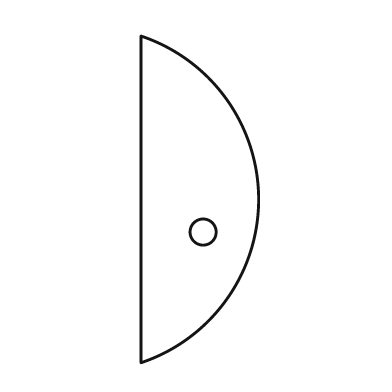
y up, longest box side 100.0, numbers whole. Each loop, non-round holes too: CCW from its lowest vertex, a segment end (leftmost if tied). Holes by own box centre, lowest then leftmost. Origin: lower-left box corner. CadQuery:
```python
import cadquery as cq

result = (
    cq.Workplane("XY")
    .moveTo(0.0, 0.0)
    .threePointArc((36.0, 50.0), (0.0, 100.0))
    .close()
    .moveTo(19.0, 40.0)
    .circle(4.0)
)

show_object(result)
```